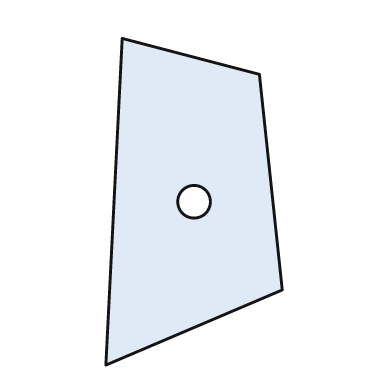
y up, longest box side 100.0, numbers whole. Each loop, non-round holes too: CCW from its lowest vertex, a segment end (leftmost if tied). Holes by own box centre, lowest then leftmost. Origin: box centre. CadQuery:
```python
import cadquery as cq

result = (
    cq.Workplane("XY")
    .moveTo(-27.0, -50.0)
    .lineTo(27.0, -27.0)
    .lineTo(20.0, 39.0)
    .lineTo(-22.0, 50.0)
    .close()
    .moveTo(0.0, 0.0)
    .circle(5.0)
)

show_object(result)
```